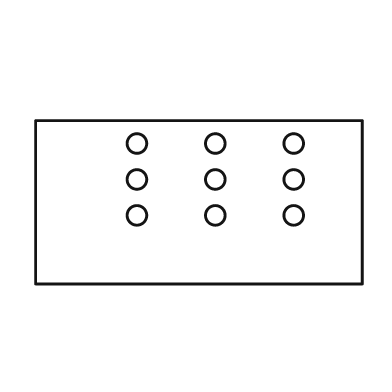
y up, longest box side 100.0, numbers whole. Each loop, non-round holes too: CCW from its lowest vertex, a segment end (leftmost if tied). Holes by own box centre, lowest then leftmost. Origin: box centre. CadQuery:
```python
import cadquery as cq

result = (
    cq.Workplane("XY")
    .moveTo(-50.0, -25.0)
    .lineTo(50.0, -25.0)
    .lineTo(50.0, 25.0)
    .lineTo(-50.0, 25.0)
    .close()
    .moveTo(-19.0, -4.0)
    .circle(3.0)
    .moveTo(5.0, -4.0)
    .circle(3.0)
    .moveTo(29.0, -4.0)
    .circle(3.0)
    .moveTo(-19.0, 7.0)
    .circle(3.0)
    .moveTo(5.0, 7.0)
    .circle(3.0)
    .moveTo(29.0, 7.0)
    .circle(3.0)
    .moveTo(-19.0, 18.0)
    .circle(3.0)
    .moveTo(5.0, 18.0)
    .circle(3.0)
    .moveTo(29.0, 18.0)
    .circle(3.0)
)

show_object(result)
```